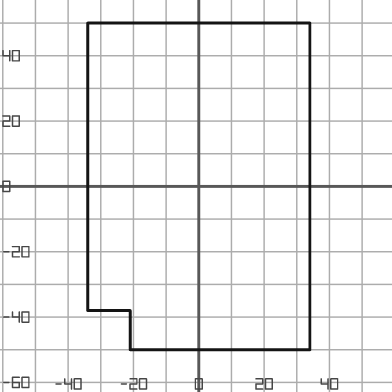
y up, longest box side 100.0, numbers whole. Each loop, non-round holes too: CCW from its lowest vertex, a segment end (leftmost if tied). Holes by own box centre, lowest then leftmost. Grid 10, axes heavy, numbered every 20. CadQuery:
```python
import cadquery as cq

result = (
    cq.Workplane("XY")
    .moveTo(-21.0, -50.0)
    .lineTo(34.0, -50.0)
    .lineTo(34.0, 50.0)
    .lineTo(-34.0, 50.0)
    .lineTo(-34.0, -38.0)
    .lineTo(-21.0, -38.0)
    .close()
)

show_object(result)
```